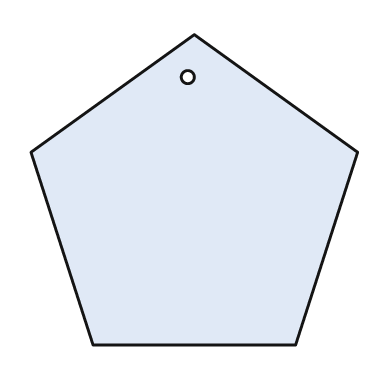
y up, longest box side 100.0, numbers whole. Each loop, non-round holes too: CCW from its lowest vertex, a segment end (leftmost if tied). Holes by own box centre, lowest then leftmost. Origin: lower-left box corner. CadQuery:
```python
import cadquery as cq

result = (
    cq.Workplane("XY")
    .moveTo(19.0, 0.0)
    .lineTo(81.0, 0.0)
    .lineTo(100.0, 59.0)
    .lineTo(50.0, 95.0)
    .lineTo(0.0, 59.0)
    .close()
    .moveTo(48.0, 82.0)
    .circle(2.0)
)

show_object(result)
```